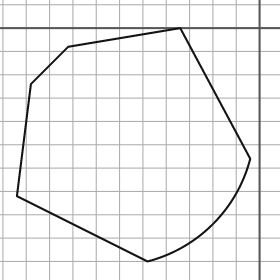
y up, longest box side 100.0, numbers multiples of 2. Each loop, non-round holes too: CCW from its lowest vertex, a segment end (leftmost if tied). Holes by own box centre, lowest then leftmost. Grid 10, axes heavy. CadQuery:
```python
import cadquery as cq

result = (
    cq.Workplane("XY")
    .moveTo(-48.0, -100.0)
    .threePointArc((-20.0, -84.0), (-4.0, -56.0))
    .lineTo(-34.0, 0.0)
    .lineTo(-82.0, -8.0)
    .lineTo(-98.0, -24.0)
    .lineTo(-104.0, -72.0)
    .close()
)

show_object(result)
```